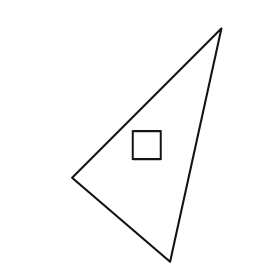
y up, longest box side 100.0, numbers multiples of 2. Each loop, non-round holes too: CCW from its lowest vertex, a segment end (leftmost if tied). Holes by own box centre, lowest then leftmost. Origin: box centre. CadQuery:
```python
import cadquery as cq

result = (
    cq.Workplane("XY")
    .moveTo(10.0, -50.0)
    .lineTo(32.0, 50.0)
    .lineTo(-32.0, -14.0)
    .close()
    .moveTo(-6.0, -6.0)
    .lineTo(6.0, -6.0)
    .lineTo(6.0, 6.0)
    .lineTo(-6.0, 6.0)
    .close()
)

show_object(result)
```